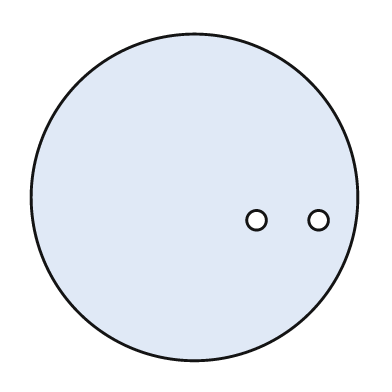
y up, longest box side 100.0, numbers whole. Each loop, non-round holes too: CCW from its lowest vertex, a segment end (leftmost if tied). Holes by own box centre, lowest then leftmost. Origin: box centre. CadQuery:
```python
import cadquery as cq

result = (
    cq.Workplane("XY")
    .moveTo(0.0, 0.0)
    .circle(50.0)
    .moveTo(19.0, -7.0)
    .circle(3.0)
    .moveTo(38.0, -7.0)
    .circle(3.0)
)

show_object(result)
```